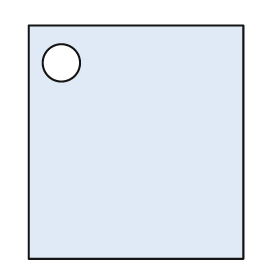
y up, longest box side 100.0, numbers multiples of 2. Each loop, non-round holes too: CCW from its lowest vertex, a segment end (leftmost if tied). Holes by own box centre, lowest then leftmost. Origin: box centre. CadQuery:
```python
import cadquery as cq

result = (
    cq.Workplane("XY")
    .moveTo(-46.0, -50.0)
    .lineTo(46.0, -50.0)
    .lineTo(46.0, 50.0)
    .lineTo(-46.0, 50.0)
    .close()
    .moveTo(-32.0, 34.0)
    .circle(8.0)
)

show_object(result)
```